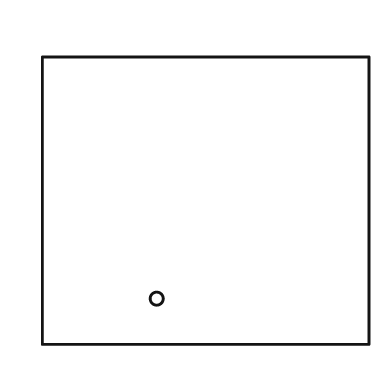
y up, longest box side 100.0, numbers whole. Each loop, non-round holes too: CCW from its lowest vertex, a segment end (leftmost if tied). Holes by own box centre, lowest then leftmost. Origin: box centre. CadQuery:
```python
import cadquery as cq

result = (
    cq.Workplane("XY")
    .moveTo(-50.0, -44.0)
    .lineTo(50.0, -44.0)
    .lineTo(50.0, 44.0)
    .lineTo(-50.0, 44.0)
    .close()
    .moveTo(-15.0, -30.0)
    .circle(2.0)
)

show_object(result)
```